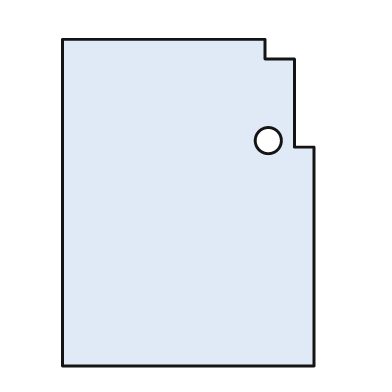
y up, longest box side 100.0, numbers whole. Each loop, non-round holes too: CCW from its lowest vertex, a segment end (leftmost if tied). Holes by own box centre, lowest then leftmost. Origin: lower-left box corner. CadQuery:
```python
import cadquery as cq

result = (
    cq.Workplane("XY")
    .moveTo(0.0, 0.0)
    .lineTo(77.0, 0.0)
    .lineTo(77.0, 67.0)
    .lineTo(71.0, 67.0)
    .lineTo(71.0, 94.0)
    .lineTo(62.0, 94.0)
    .lineTo(62.0, 100.0)
    .lineTo(0.0, 100.0)
    .close()
    .moveTo(63.0, 69.0)
    .circle(4.0)
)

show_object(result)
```